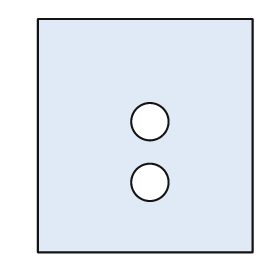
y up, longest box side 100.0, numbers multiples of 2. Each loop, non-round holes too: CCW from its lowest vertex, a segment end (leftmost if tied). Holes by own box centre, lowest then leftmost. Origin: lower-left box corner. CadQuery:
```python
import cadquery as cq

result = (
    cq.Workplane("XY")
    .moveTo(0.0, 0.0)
    .lineTo(92.0, 0.0)
    .lineTo(92.0, 100.0)
    .lineTo(0.0, 100.0)
    .close()
    .moveTo(48.0, 30.0)
    .circle(8.0)
    .moveTo(48.0, 56.0)
    .circle(8.0)
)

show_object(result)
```